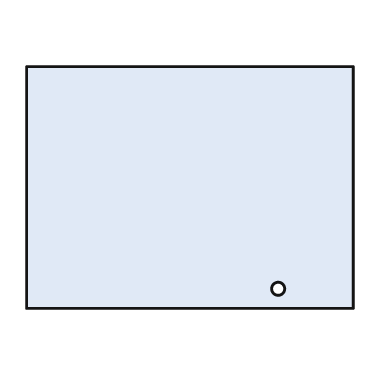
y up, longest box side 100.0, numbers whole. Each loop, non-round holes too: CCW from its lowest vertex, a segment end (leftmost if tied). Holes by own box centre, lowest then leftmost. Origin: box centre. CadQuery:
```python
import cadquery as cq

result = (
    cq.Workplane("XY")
    .moveTo(-50.0, -37.0)
    .lineTo(50.0, -37.0)
    .lineTo(50.0, 37.0)
    .lineTo(-50.0, 37.0)
    .close()
    .moveTo(27.0, -31.0)
    .circle(2.0)
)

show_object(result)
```